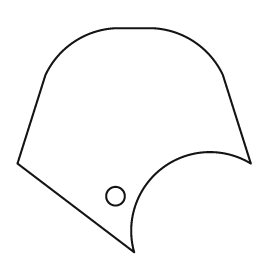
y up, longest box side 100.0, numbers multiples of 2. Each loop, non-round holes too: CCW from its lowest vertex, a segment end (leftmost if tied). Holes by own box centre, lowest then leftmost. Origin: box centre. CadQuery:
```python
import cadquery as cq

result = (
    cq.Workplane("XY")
    .moveTo(0.0, -48.0)
    .threePointArc((12.0, -12.0), (50.0, -10.0))
    .lineTo(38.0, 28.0)
    .threePointArc((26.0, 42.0), (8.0, 48.0))
    .lineTo(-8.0, 48.0)
    .threePointArc((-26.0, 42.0), (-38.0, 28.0))
    .lineTo(-50.0, -10.0)
    .close()
    .moveTo(-8.0, -24.0)
    .circle(4.0)
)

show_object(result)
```